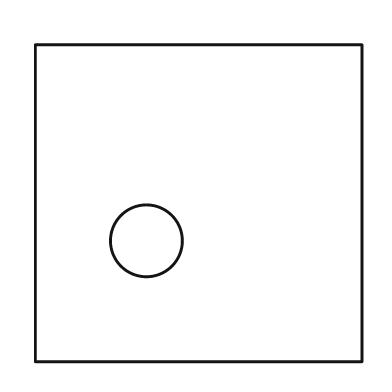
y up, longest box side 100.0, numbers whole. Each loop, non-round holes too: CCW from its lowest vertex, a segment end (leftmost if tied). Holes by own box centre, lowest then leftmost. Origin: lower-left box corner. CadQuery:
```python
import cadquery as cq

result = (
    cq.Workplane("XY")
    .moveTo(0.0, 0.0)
    .lineTo(100.0, 0.0)
    .lineTo(100.0, 97.0)
    .lineTo(0.0, 97.0)
    .close()
    .moveTo(34.0, 37.0)
    .circle(11.0)
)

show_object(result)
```